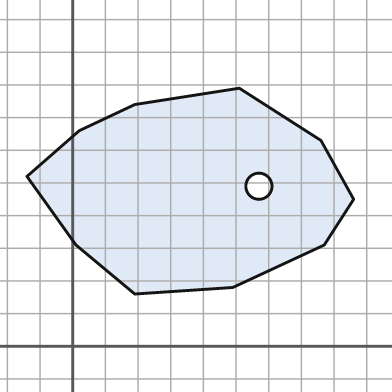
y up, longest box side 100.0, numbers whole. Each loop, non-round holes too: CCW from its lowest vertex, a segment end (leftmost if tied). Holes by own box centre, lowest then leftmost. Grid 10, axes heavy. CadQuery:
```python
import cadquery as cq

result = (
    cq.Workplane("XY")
    .moveTo(19.0, 16.0)
    .lineTo(49.0, 18.0)
    .lineTo(77.0, 31.0)
    .lineTo(86.0, 45.0)
    .lineTo(76.0, 63.0)
    .lineTo(51.0, 79.0)
    .lineTo(19.0, 74.0)
    .lineTo(2.0, 66.0)
    .lineTo(-14.0, 52.0)
    .lineTo(1.0, 31.0)
    .close()
    .moveTo(57.0, 49.0)
    .circle(4.0)
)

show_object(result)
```